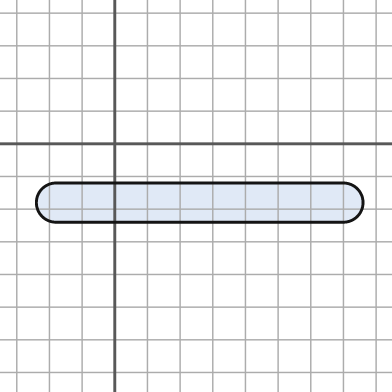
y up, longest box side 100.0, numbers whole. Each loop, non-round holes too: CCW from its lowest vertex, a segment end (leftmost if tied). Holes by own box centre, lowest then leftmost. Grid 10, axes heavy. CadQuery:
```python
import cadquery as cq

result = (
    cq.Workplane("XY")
    .moveTo(-18.0, -24.0)
    .lineTo(70.0, -24.0)
    .threePointArc((76.0, -18.0), (70.0, -12.0))
    .lineTo(-18.0, -12.0)
    .threePointArc((-24.0, -18.0), (-18.0, -24.0))
    .close()
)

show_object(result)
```